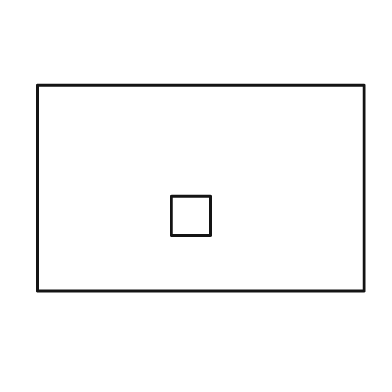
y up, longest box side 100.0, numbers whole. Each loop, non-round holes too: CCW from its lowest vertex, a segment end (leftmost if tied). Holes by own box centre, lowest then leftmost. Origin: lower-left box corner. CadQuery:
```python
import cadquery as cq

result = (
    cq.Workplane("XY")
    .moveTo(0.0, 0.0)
    .lineTo(100.0, 0.0)
    .lineTo(100.0, 63.0)
    .lineTo(0.0, 63.0)
    .close()
    .moveTo(41.0, 17.0)
    .lineTo(53.0, 17.0)
    .lineTo(53.0, 29.0)
    .lineTo(41.0, 29.0)
    .close()
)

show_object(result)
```